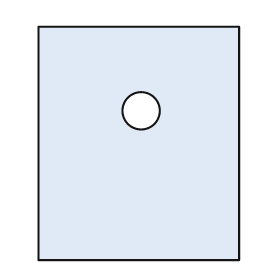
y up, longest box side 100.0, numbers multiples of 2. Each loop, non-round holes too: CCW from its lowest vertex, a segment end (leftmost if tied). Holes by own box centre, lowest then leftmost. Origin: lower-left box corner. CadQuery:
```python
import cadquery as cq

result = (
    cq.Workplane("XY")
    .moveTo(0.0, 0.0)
    .lineTo(86.0, 0.0)
    .lineTo(86.0, 100.0)
    .lineTo(0.0, 100.0)
    .close()
    .moveTo(44.0, 64.0)
    .circle(8.0)
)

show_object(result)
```